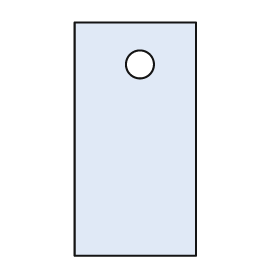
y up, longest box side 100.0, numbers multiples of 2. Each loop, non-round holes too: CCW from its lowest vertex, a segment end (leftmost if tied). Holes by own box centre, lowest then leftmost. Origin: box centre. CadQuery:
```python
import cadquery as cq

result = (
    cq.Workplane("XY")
    .moveTo(-26.0, -50.0)
    .lineTo(26.0, -50.0)
    .lineTo(26.0, 50.0)
    .lineTo(-26.0, 50.0)
    .close()
    .moveTo(2.0, 32.0)
    .circle(6.0)
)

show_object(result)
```